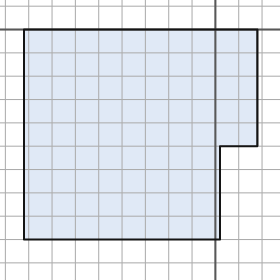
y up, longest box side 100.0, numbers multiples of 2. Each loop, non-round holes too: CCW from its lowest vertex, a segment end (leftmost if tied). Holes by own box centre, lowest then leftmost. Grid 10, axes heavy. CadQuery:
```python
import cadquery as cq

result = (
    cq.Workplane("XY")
    .moveTo(-82.0, -90.0)
    .lineTo(2.0, -90.0)
    .lineTo(2.0, -50.0)
    .lineTo(18.0, -50.0)
    .lineTo(18.0, 0.0)
    .lineTo(-82.0, 0.0)
    .close()
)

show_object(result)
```